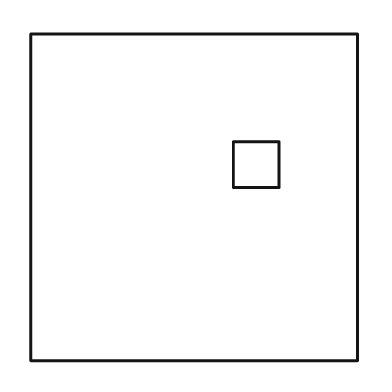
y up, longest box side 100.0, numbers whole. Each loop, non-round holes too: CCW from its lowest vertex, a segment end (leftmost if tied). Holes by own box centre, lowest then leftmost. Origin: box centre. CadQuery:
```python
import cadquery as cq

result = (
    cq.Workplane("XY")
    .moveTo(-50.0, -50.0)
    .lineTo(50.0, -50.0)
    .lineTo(50.0, 50.0)
    .lineTo(-50.0, 50.0)
    .close()
    .moveTo(12.0, 3.0)
    .lineTo(26.0, 3.0)
    .lineTo(26.0, 17.0)
    .lineTo(12.0, 17.0)
    .close()
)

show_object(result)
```